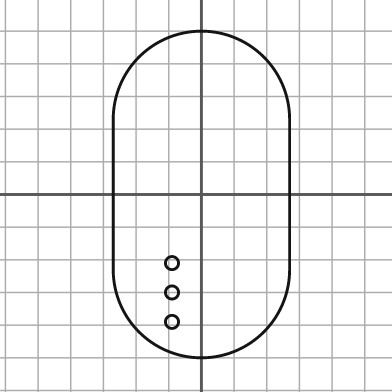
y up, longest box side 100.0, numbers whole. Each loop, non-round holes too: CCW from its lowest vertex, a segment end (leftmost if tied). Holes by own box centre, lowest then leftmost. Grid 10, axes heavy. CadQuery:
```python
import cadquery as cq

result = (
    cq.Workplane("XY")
    .moveTo(-27.0, -23.0)
    .threePointArc((0.0, -50.0), (27.0, -23.0))
    .lineTo(27.0, 23.0)
    .threePointArc((0.0, 50.0), (-27.0, 23.0))
    .close()
    .moveTo(-9.0, -39.0)
    .circle(2.0)
    .moveTo(-9.0, -30.0)
    .circle(2.0)
    .moveTo(-9.0, -21.0)
    .circle(2.0)
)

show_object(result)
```